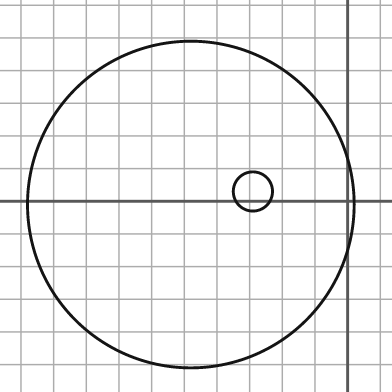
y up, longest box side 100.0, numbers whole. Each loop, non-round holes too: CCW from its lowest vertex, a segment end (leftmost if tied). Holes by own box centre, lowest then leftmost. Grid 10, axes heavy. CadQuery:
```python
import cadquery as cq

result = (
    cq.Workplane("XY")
    .moveTo(-48.0, -1.0)
    .circle(50.0)
    .moveTo(-29.0, 3.0)
    .circle(6.0)
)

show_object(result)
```